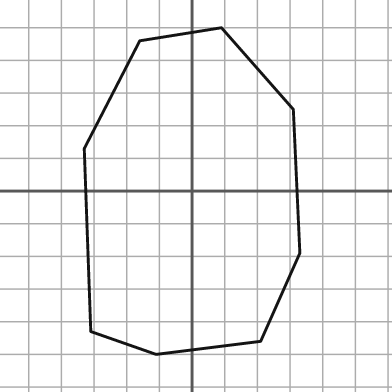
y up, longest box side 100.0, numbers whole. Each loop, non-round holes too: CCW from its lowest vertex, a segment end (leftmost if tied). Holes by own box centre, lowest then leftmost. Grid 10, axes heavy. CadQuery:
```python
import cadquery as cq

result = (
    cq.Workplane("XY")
    .moveTo(-11.0, -50.0)
    .lineTo(21.0, -46.0)
    .lineTo(33.0, -19.0)
    .lineTo(31.0, 25.0)
    .lineTo(9.0, 50.0)
    .lineTo(-16.0, 46.0)
    .lineTo(-33.0, 13.0)
    .lineTo(-31.0, -43.0)
    .close()
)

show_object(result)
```